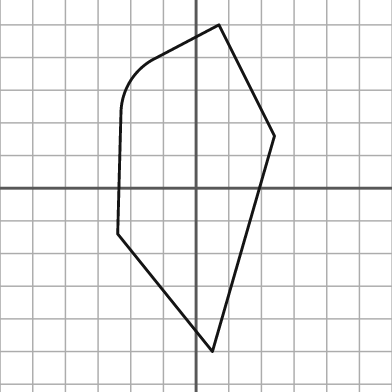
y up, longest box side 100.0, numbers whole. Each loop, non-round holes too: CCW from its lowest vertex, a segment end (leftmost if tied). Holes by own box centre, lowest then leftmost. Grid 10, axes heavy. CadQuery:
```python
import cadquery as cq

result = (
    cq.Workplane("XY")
    .moveTo(5.0, -50.0)
    .lineTo(24.0, 16.0)
    .lineTo(7.0, 50.0)
    .lineTo(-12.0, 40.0)
    .threePointArc((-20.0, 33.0), (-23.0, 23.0))
    .lineTo(-24.0, -14.0)
    .close()
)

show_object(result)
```